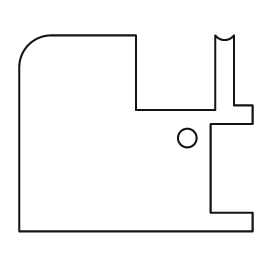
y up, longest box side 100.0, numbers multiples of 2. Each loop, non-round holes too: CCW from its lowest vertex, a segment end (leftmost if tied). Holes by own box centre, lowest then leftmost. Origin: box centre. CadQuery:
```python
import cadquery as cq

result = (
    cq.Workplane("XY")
    .moveTo(-50.0, -42.0)
    .lineTo(50.0, -42.0)
    .lineTo(50.0, -34.0)
    .lineTo(32.0, -34.0)
    .lineTo(32.0, 4.0)
    .lineTo(50.0, 4.0)
    .lineTo(50.0, 12.0)
    .lineTo(42.0, 12.0)
    .lineTo(42.0, 42.0)
    .threePointArc((38.0, 40.0), (34.0, 42.0))
    .lineTo(34.0, 10.0)
    .lineTo(0.0, 10.0)
    .lineTo(0.0, 42.0)
    .lineTo(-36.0, 42.0)
    .threePointArc((-46.0, 38.0), (-50.0, 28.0))
    .close()
    .moveTo(22.0, -2.0)
    .circle(4.0)
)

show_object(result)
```